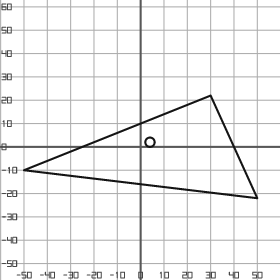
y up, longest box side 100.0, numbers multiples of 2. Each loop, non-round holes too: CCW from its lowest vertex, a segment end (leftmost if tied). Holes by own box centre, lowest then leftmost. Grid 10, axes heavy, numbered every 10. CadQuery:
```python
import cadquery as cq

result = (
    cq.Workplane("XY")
    .moveTo(50.0, -22.0)
    .lineTo(30.0, 22.0)
    .lineTo(-50.0, -10.0)
    .close()
    .moveTo(4.0, 2.0)
    .circle(2.0)
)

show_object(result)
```